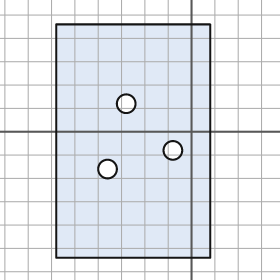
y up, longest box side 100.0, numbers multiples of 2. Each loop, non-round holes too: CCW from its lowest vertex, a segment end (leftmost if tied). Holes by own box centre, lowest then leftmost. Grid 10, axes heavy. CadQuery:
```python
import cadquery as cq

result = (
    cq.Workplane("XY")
    .moveTo(-58.0, -54.0)
    .lineTo(8.0, -54.0)
    .lineTo(8.0, 46.0)
    .lineTo(-58.0, 46.0)
    .close()
    .moveTo(-36.0, -16.0)
    .circle(4.0)
    .moveTo(-8.0, -8.0)
    .circle(4.0)
    .moveTo(-28.0, 12.0)
    .circle(4.0)
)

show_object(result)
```